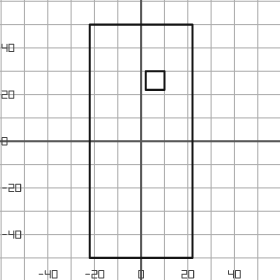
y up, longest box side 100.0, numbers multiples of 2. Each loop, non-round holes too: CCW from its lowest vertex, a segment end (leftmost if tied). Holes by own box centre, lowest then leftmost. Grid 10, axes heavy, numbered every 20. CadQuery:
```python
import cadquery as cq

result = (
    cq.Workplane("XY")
    .moveTo(-22.0, -50.0)
    .lineTo(22.0, -50.0)
    .lineTo(22.0, 50.0)
    .lineTo(-22.0, 50.0)
    .close()
    .moveTo(2.0, 22.0)
    .lineTo(10.0, 22.0)
    .lineTo(10.0, 30.0)
    .lineTo(2.0, 30.0)
    .close()
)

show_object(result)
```